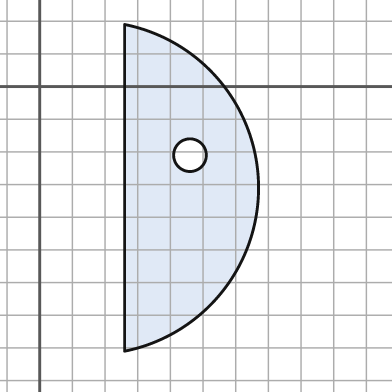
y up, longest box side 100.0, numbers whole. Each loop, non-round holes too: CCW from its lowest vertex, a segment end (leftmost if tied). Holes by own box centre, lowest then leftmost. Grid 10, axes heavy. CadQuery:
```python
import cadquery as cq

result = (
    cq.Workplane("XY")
    .moveTo(26.0, -81.0)
    .threePointArc((67.0, -31.0), (26.0, 19.0))
    .close()
    .moveTo(46.0, -21.0)
    .circle(5.0)
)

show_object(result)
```